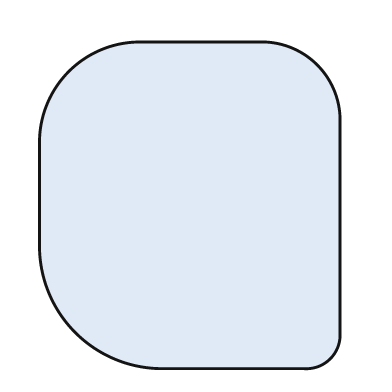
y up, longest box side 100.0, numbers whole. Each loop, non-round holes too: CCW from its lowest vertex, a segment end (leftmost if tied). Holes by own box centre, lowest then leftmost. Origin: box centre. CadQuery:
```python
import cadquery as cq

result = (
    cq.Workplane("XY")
    .moveTo(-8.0, -50.0)
    .lineTo(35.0, -50.0)
    .threePointArc((43.0, -47.0), (46.0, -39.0))
    .lineTo(46.0, 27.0)
    .threePointArc((39.0, 43.0), (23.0, 50.0))
    .lineTo(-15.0, 50.0)
    .threePointArc((-37.0, 41.0), (-46.0, 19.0))
    .lineTo(-46.0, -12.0)
    .threePointArc((-35.0, -39.0), (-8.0, -50.0))
    .close()
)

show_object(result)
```